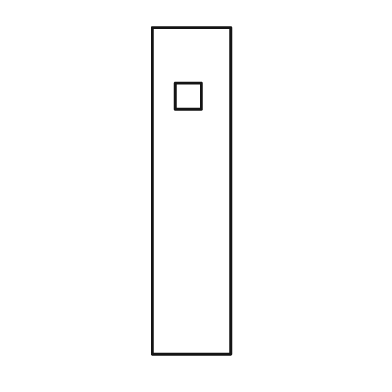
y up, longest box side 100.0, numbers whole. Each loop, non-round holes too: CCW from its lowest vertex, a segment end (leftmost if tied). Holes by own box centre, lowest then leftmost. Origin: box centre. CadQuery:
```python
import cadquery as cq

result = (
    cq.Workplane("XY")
    .moveTo(-12.0, -50.0)
    .lineTo(12.0, -50.0)
    .lineTo(12.0, 50.0)
    .lineTo(-12.0, 50.0)
    .close()
    .moveTo(-5.0, 25.0)
    .lineTo(3.0, 25.0)
    .lineTo(3.0, 33.0)
    .lineTo(-5.0, 33.0)
    .close()
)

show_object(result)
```